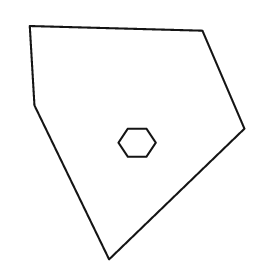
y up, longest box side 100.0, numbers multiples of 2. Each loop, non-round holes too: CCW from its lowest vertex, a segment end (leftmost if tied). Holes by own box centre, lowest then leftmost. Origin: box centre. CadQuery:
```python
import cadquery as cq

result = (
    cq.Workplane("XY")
    .moveTo(-12.0, -50.0)
    .lineTo(46.0, 6.0)
    .lineTo(28.0, 48.0)
    .lineTo(-46.0, 50.0)
    .lineTo(-44.0, 16.0)
    .close()
    .moveTo(-4.0, -6.0)
    .lineTo(4.0, -6.0)
    .lineTo(8.0, 0.0)
    .lineTo(4.0, 6.0)
    .lineTo(-4.0, 6.0)
    .lineTo(-8.0, 0.0)
    .close()
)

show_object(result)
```